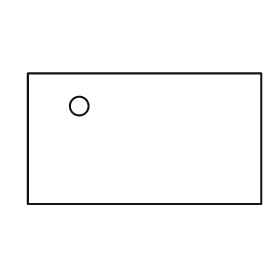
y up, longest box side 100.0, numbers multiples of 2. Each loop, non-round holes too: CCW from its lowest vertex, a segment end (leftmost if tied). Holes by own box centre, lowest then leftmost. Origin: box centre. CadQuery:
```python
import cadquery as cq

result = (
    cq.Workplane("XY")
    .moveTo(-50.0, -28.0)
    .lineTo(50.0, -28.0)
    .lineTo(50.0, 28.0)
    .lineTo(-50.0, 28.0)
    .close()
    .moveTo(-28.0, 14.0)
    .circle(4.0)
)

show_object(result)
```